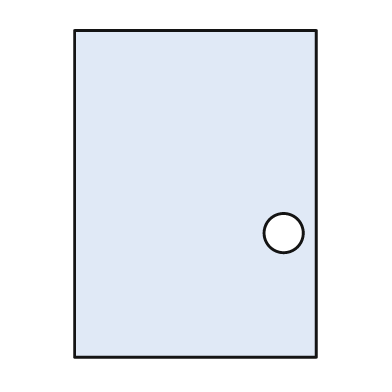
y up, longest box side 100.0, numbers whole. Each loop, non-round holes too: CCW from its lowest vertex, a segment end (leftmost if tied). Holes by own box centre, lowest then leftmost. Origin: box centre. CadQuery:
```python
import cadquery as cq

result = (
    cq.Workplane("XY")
    .moveTo(-37.0, -50.0)
    .lineTo(37.0, -50.0)
    .lineTo(37.0, 50.0)
    .lineTo(-37.0, 50.0)
    .close()
    .moveTo(27.0, -12.0)
    .circle(6.0)
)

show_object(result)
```